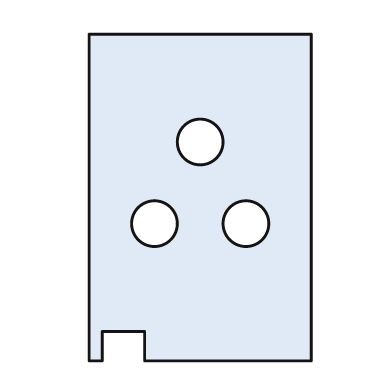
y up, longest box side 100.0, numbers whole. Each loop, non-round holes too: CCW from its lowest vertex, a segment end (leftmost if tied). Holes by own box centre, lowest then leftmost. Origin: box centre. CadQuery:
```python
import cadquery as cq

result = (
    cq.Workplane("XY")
    .moveTo(-34.0, -50.0)
    .lineTo(-30.0, -50.0)
    .lineTo(-30.0, -41.0)
    .lineTo(-17.0, -41.0)
    .lineTo(-17.0, -50.0)
    .lineTo(34.0, -50.0)
    .lineTo(34.0, 50.0)
    .lineTo(-34.0, 50.0)
    .close()
    .moveTo(-14.0, -8.0)
    .circle(7.0)
    .moveTo(14.0, -8.0)
    .circle(7.0)
    .moveTo(0.0, 17.0)
    .circle(7.0)
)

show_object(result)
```